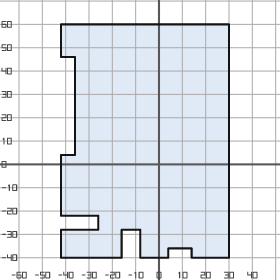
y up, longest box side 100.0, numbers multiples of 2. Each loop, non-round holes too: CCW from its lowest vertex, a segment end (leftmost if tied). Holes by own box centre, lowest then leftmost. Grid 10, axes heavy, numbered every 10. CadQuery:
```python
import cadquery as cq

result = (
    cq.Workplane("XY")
    .moveTo(-42.0, -40.0)
    .lineTo(-16.0, -40.0)
    .lineTo(-16.0, -28.0)
    .lineTo(-8.0, -28.0)
    .lineTo(-8.0, -40.0)
    .lineTo(4.0, -40.0)
    .lineTo(4.0, -36.0)
    .lineTo(14.0, -36.0)
    .lineTo(14.0, -40.0)
    .lineTo(30.0, -40.0)
    .lineTo(30.0, 60.0)
    .lineTo(-42.0, 60.0)
    .lineTo(-42.0, 46.0)
    .lineTo(-36.0, 46.0)
    .lineTo(-36.0, 4.0)
    .lineTo(-42.0, 4.0)
    .lineTo(-42.0, -22.0)
    .lineTo(-26.0, -22.0)
    .lineTo(-26.0, -28.0)
    .lineTo(-42.0, -28.0)
    .close()
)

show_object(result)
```